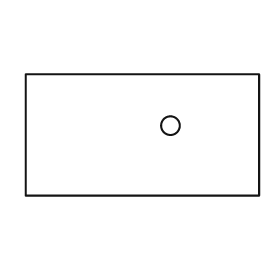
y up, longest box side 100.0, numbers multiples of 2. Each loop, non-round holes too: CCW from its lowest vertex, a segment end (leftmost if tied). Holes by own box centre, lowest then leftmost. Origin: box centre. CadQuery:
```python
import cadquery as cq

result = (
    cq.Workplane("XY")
    .moveTo(-50.0, -26.0)
    .lineTo(50.0, -26.0)
    .lineTo(50.0, 26.0)
    .lineTo(-50.0, 26.0)
    .close()
    .moveTo(12.0, 4.0)
    .circle(4.0)
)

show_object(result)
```